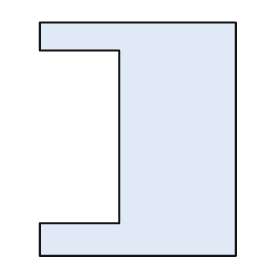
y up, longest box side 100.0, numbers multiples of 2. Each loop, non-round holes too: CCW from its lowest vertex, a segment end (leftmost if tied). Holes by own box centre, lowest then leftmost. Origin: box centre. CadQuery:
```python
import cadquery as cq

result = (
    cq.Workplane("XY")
    .moveTo(-42.0, -50.0)
    .lineTo(42.0, -50.0)
    .lineTo(42.0, 50.0)
    .lineTo(-42.0, 50.0)
    .lineTo(-42.0, 38.0)
    .lineTo(-8.0, 38.0)
    .lineTo(-8.0, -36.0)
    .lineTo(-42.0, -36.0)
    .close()
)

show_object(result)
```